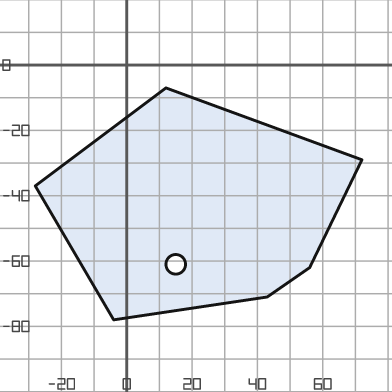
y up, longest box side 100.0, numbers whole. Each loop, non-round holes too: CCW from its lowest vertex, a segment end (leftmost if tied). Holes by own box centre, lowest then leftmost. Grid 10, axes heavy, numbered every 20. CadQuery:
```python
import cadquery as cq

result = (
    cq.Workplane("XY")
    .moveTo(-4.0, -78.0)
    .lineTo(43.0, -71.0)
    .lineTo(56.0, -62.0)
    .lineTo(72.0, -29.0)
    .lineTo(12.0, -7.0)
    .lineTo(-28.0, -37.0)
    .close()
    .moveTo(15.0, -61.0)
    .circle(3.0)
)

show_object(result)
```